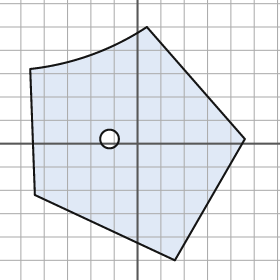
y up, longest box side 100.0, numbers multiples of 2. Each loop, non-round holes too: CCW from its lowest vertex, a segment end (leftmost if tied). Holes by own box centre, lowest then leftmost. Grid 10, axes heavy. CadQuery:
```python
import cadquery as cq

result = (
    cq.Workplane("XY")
    .moveTo(16.0, -50.0)
    .lineTo(46.0, 2.0)
    .lineTo(4.0, 50.0)
    .threePointArc((-20.0, 38.0), (-46.0, 32.0))
    .lineTo(-44.0, -22.0)
    .close()
    .moveTo(-12.0, 2.0)
    .circle(4.0)
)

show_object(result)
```